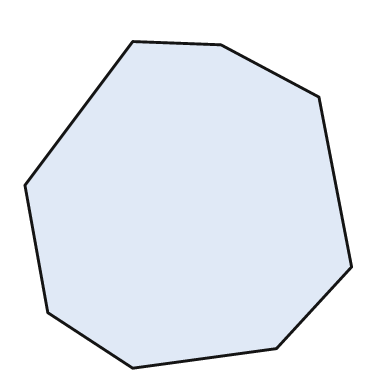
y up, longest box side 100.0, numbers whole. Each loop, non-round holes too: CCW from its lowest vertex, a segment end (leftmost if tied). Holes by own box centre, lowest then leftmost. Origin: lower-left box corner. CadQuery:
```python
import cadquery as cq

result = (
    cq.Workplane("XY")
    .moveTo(33.0, 0.0)
    .lineTo(77.0, 6.0)
    .lineTo(100.0, 31.0)
    .lineTo(90.0, 83.0)
    .lineTo(60.0, 99.0)
    .lineTo(33.0, 100.0)
    .lineTo(0.0, 56.0)
    .lineTo(7.0, 17.0)
    .close()
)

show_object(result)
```